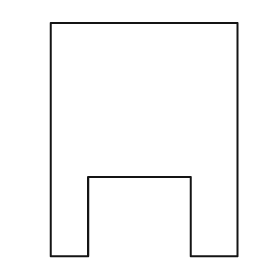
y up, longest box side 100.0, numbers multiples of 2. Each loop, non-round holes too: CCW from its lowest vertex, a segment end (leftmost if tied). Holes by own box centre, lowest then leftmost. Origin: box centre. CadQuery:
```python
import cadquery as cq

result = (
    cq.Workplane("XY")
    .moveTo(-40.0, -50.0)
    .lineTo(-24.0, -50.0)
    .lineTo(-24.0, -16.0)
    .lineTo(20.0, -16.0)
    .lineTo(20.0, -50.0)
    .lineTo(40.0, -50.0)
    .lineTo(40.0, 50.0)
    .lineTo(-40.0, 50.0)
    .close()
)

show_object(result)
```